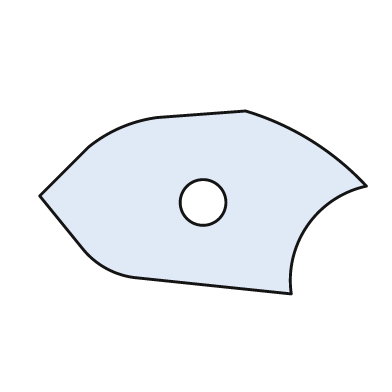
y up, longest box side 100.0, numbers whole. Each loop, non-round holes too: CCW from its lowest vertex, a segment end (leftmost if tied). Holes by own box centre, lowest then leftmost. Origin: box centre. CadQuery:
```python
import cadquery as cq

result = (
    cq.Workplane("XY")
    .moveTo(27.0, -28.0)
    .threePointArc((32.0, -7.0), (50.0, 5.0))
    .threePointArc((33.0, 19.0), (13.0, 28.0))
    .lineTo(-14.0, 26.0)
    .threePointArc((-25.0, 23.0), (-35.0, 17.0))
    .lineTo(-50.0, 2.0)
    .lineTo(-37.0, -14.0)
    .threePointArc((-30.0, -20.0), (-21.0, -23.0))
    .close()
    .moveTo(0.0, 0.0)
    .circle(7.0)
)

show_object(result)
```